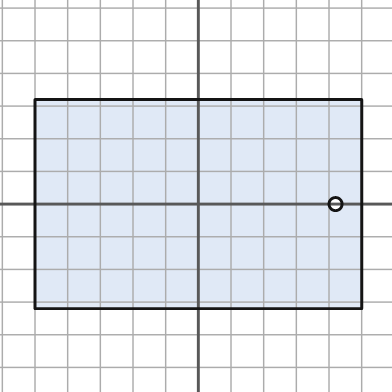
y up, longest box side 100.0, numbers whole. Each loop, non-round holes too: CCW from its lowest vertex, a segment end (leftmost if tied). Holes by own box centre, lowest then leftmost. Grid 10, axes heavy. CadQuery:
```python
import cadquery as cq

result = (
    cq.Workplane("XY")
    .moveTo(-50.0, -32.0)
    .lineTo(50.0, -32.0)
    .lineTo(50.0, 32.0)
    .lineTo(-50.0, 32.0)
    .close()
    .moveTo(42.0, 0.0)
    .circle(2.0)
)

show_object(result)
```